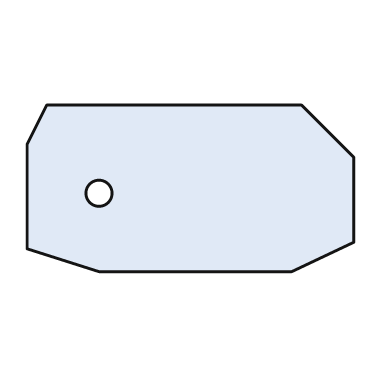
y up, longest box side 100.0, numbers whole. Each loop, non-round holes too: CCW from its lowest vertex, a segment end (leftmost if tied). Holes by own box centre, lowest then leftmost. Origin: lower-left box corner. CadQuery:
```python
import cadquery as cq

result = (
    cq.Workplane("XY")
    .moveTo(22.0, 0.0)
    .lineTo(81.0, 0.0)
    .lineTo(100.0, 9.0)
    .lineTo(100.0, 35.0)
    .lineTo(84.0, 51.0)
    .lineTo(6.0, 51.0)
    .lineTo(0.0, 39.0)
    .lineTo(0.0, 7.0)
    .close()
    .moveTo(22.0, 24.0)
    .circle(4.0)
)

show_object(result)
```